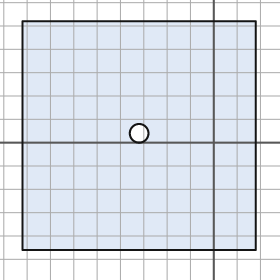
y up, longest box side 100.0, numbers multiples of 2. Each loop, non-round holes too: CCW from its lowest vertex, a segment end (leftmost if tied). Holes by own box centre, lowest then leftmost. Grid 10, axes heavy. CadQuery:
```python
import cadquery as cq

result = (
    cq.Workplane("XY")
    .moveTo(-82.0, -46.0)
    .lineTo(18.0, -46.0)
    .lineTo(18.0, 52.0)
    .lineTo(-82.0, 52.0)
    .close()
    .moveTo(-32.0, 4.0)
    .circle(4.0)
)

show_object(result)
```